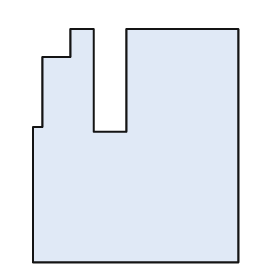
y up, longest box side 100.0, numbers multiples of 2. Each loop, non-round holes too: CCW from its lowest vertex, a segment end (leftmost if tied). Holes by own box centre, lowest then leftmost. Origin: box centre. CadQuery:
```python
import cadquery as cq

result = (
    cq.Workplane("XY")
    .moveTo(-44.0, -50.0)
    .lineTo(44.0, -50.0)
    .lineTo(44.0, 50.0)
    .lineTo(-4.0, 50.0)
    .lineTo(-4.0, 6.0)
    .lineTo(-18.0, 6.0)
    .lineTo(-18.0, 50.0)
    .lineTo(-28.0, 50.0)
    .lineTo(-28.0, 38.0)
    .lineTo(-40.0, 38.0)
    .lineTo(-40.0, 8.0)
    .lineTo(-44.0, 8.0)
    .close()
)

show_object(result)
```